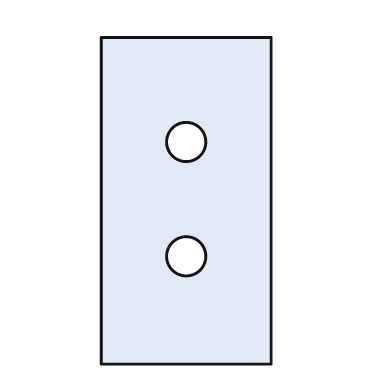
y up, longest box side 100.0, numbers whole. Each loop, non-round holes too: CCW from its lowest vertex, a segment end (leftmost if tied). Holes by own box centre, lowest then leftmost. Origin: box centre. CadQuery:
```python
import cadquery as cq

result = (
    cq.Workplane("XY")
    .moveTo(-26.0, -50.0)
    .lineTo(26.0, -50.0)
    .lineTo(26.0, 50.0)
    .lineTo(-26.0, 50.0)
    .close()
    .moveTo(0.0, -17.0)
    .circle(6.0)
    .moveTo(0.0, 18.0)
    .circle(6.0)
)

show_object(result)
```